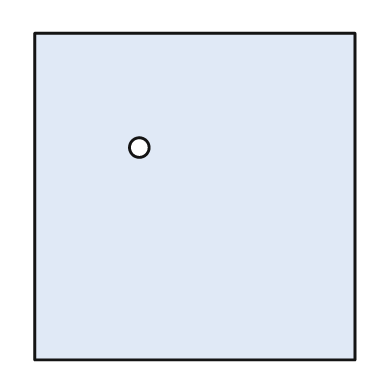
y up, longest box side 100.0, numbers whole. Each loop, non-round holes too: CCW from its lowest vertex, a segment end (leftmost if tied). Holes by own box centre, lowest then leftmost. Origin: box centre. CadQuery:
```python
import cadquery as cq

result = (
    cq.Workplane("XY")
    .moveTo(-49.0, -50.0)
    .lineTo(49.0, -50.0)
    .lineTo(49.0, 50.0)
    .lineTo(-49.0, 50.0)
    .close()
    .moveTo(-17.0, 15.0)
    .circle(3.0)
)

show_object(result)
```